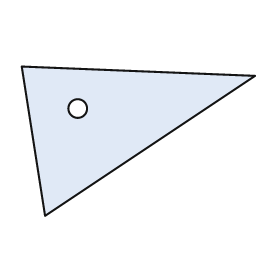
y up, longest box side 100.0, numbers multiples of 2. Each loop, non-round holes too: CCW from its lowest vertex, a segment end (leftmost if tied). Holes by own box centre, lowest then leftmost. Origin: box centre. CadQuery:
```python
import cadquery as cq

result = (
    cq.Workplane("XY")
    .moveTo(-40.0, -32.0)
    .lineTo(50.0, 28.0)
    .lineTo(-50.0, 32.0)
    .close()
    .moveTo(-26.0, 14.0)
    .circle(4.0)
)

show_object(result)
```